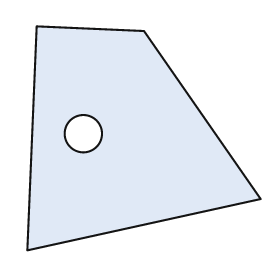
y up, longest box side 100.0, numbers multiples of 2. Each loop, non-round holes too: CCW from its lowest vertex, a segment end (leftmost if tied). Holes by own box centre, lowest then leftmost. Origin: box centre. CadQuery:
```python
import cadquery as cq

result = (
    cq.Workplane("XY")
    .moveTo(-50.0, -48.0)
    .lineTo(50.0, -26.0)
    .lineTo(0.0, 46.0)
    .lineTo(-46.0, 48.0)
    .close()
    .moveTo(-26.0, 2.0)
    .circle(8.0)
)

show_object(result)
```